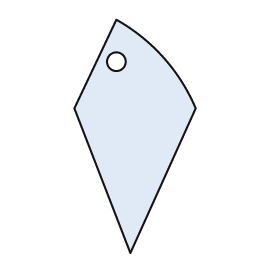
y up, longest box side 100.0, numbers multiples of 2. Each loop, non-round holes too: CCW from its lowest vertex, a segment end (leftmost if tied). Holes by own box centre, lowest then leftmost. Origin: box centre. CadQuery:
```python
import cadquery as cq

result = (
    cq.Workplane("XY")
    .moveTo(-2.0, -50.0)
    .lineTo(26.0, 12.0)
    .threePointArc((12.0, 34.0), (-8.0, 50.0))
    .lineTo(-26.0, 12.0)
    .close()
    .moveTo(-8.0, 32.0)
    .circle(4.0)
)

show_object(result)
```